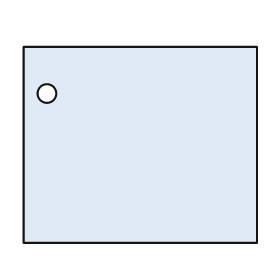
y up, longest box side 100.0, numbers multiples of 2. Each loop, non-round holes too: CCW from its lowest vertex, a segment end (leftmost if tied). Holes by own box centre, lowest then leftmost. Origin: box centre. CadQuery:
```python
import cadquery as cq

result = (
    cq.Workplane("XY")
    .moveTo(-50.0, -42.0)
    .lineTo(50.0, -42.0)
    .lineTo(50.0, 42.0)
    .lineTo(-50.0, 42.0)
    .close()
    .moveTo(-40.0, 22.0)
    .circle(4.0)
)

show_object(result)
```